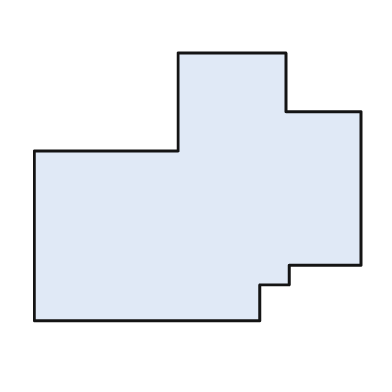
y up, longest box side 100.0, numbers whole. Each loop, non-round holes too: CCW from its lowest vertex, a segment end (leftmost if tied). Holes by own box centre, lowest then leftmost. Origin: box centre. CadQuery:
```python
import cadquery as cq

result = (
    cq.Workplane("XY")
    .moveTo(-50.0, -41.0)
    .lineTo(19.0, -41.0)
    .lineTo(19.0, -30.0)
    .lineTo(28.0, -30.0)
    .lineTo(28.0, -24.0)
    .lineTo(50.0, -24.0)
    .lineTo(50.0, 23.0)
    .lineTo(27.0, 23.0)
    .lineTo(27.0, 41.0)
    .lineTo(-6.0, 41.0)
    .lineTo(-6.0, 11.0)
    .lineTo(-50.0, 11.0)
    .close()
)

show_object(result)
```